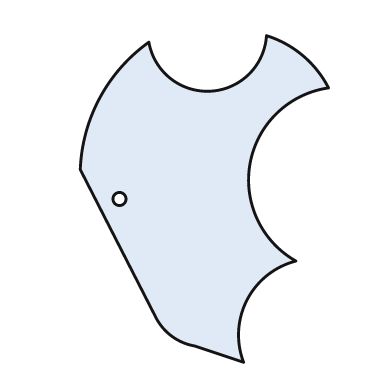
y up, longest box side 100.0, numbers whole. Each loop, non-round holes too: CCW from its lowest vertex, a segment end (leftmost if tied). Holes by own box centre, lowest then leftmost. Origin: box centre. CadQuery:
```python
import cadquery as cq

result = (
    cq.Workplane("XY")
    .moveTo(12.0, -50.0)
    .threePointArc((13.0, -31.0), (28.0, -19.0))
    .threePointArc((14.0, 11.0), (38.0, 34.0))
    .threePointArc((30.0, 44.0), (19.0, 50.0))
    .threePointArc((2.0, 33.0), (-17.0, 48.0))
    .threePointArc((-32.0, 31.0), (-38.0, 9.0))
    .lineTo(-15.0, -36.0)
    .threePointArc((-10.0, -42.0), (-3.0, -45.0))
    .close()
    .moveTo(-26.0, 0.0)
    .circle(2.0)
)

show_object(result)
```